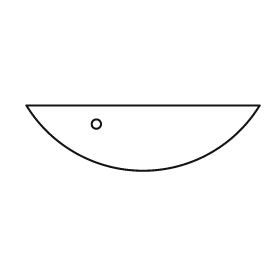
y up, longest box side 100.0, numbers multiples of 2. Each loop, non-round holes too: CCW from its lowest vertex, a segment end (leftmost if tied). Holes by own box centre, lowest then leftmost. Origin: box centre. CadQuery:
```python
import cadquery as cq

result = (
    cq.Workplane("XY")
    .moveTo(-50.0, 14.0)
    .threePointArc((0.0, -14.0), (50.0, 14.0))
    .close()
    .moveTo(-20.0, 6.0)
    .circle(2.0)
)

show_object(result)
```